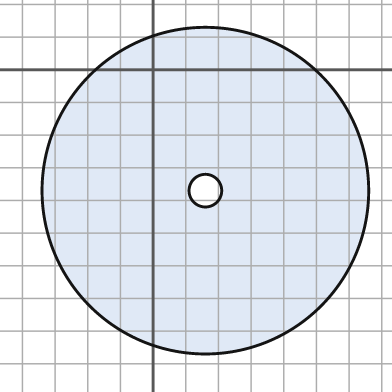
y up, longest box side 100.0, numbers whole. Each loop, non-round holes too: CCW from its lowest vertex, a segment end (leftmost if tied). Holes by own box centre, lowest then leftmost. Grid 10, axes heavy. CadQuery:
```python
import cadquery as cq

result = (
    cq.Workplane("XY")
    .moveTo(16.0, -37.0)
    .circle(50.0)
    .moveTo(16.0, -37.0)
    .circle(5.0)
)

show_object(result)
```